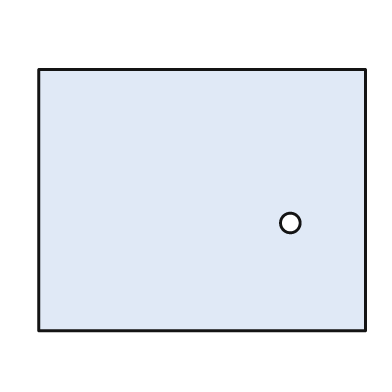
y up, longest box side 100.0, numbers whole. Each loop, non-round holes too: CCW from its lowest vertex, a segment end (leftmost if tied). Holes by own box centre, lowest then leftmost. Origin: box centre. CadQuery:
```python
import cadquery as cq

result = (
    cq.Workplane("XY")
    .moveTo(-50.0, -40.0)
    .lineTo(50.0, -40.0)
    .lineTo(50.0, 40.0)
    .lineTo(-50.0, 40.0)
    .close()
    .moveTo(27.0, -7.0)
    .circle(3.0)
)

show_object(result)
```